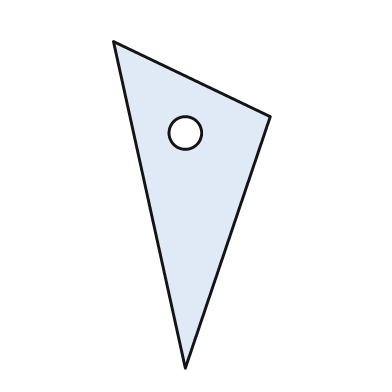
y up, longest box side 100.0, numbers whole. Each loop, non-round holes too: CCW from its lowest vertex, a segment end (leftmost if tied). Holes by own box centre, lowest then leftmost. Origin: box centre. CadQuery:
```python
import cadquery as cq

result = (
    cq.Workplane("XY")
    .moveTo(-2.0, -50.0)
    .lineTo(24.0, 27.0)
    .lineTo(-24.0, 50.0)
    .close()
    .moveTo(-2.0, 22.0)
    .circle(5.0)
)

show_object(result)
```